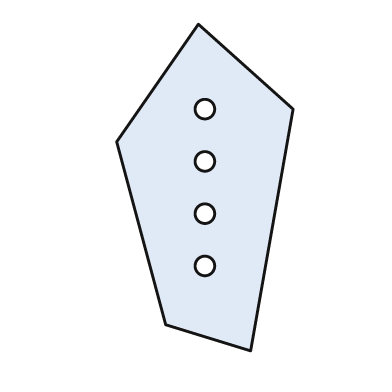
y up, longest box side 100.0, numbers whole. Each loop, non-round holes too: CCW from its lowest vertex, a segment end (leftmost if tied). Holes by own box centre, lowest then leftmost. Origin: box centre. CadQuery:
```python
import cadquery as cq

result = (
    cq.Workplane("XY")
    .moveTo(14.0, -50.0)
    .lineTo(27.0, 24.0)
    .lineTo(-2.0, 50.0)
    .lineTo(-27.0, 14.0)
    .lineTo(-12.0, -42.0)
    .close()
    .moveTo(0.0, -24.0)
    .circle(3.0)
    .moveTo(0.0, -8.0)
    .circle(3.0)
    .moveTo(0.0, 8.0)
    .circle(3.0)
    .moveTo(0.0, 24.0)
    .circle(3.0)
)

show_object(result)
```